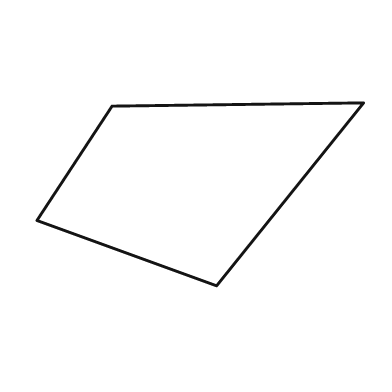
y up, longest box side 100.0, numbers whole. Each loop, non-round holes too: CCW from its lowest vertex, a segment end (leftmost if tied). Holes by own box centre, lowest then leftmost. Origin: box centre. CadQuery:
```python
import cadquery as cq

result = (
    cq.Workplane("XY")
    .moveTo(5.0, -28.0)
    .lineTo(50.0, 28.0)
    .lineTo(-27.0, 27.0)
    .lineTo(-50.0, -8.0)
    .close()
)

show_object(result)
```